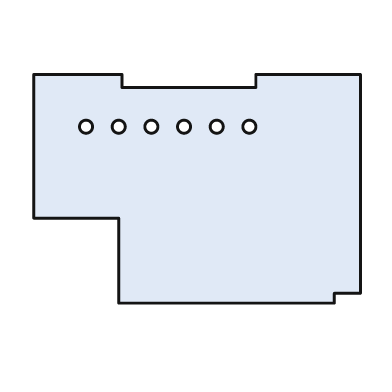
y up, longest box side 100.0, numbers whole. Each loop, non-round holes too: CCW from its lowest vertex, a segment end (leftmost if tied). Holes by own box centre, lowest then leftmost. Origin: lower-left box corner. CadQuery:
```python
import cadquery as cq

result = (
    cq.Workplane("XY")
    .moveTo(26.0, 0.0)
    .lineTo(92.0, 0.0)
    .lineTo(92.0, 3.0)
    .lineTo(100.0, 3.0)
    .lineTo(100.0, 70.0)
    .lineTo(68.0, 70.0)
    .lineTo(68.0, 66.0)
    .lineTo(27.0, 66.0)
    .lineTo(27.0, 70.0)
    .lineTo(0.0, 70.0)
    .lineTo(0.0, 26.0)
    .lineTo(26.0, 26.0)
    .close()
    .moveTo(16.0, 54.0)
    .circle(2.0)
    .moveTo(26.0, 54.0)
    .circle(2.0)
    .moveTo(36.0, 54.0)
    .circle(2.0)
    .moveTo(46.0, 54.0)
    .circle(2.0)
    .moveTo(56.0, 54.0)
    .circle(2.0)
    .moveTo(66.0, 54.0)
    .circle(2.0)
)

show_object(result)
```